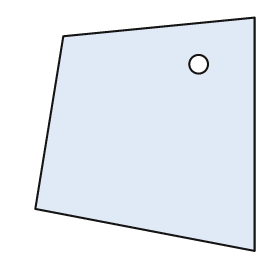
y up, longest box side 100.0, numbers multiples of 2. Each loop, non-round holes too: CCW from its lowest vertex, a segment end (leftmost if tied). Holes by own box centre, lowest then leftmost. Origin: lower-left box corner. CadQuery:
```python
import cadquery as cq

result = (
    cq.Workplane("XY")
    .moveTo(94.0, 0.0)
    .lineTo(94.0, 100.0)
    .lineTo(12.0, 92.0)
    .lineTo(0.0, 18.0)
    .close()
    .moveTo(70.0, 80.0)
    .circle(4.0)
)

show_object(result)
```